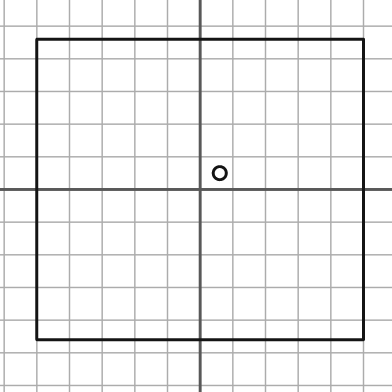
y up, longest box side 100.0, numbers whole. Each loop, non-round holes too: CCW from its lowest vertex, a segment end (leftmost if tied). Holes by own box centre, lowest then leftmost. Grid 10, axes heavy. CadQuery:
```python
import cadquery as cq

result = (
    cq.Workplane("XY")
    .moveTo(-50.0, -46.0)
    .lineTo(50.0, -46.0)
    .lineTo(50.0, 46.0)
    .lineTo(-50.0, 46.0)
    .close()
    .moveTo(6.0, 5.0)
    .circle(2.0)
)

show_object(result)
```